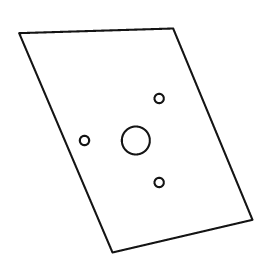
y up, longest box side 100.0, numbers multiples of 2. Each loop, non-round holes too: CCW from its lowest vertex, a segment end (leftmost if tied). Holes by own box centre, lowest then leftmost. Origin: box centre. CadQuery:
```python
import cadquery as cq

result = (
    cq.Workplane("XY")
    .moveTo(-10.0, -48.0)
    .lineTo(50.0, -34.0)
    .lineTo(16.0, 48.0)
    .lineTo(-50.0, 46.0)
    .close()
    .moveTo(10.0, -18.0)
    .circle(2.0)
    .moveTo(-22.0, 0.0)
    .circle(2.0)
    .moveTo(0.0, 0.0)
    .circle(6.0)
    .moveTo(10.0, 18.0)
    .circle(2.0)
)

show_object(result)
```